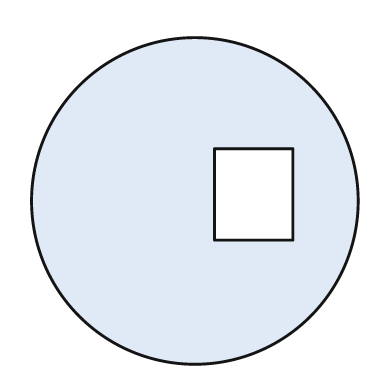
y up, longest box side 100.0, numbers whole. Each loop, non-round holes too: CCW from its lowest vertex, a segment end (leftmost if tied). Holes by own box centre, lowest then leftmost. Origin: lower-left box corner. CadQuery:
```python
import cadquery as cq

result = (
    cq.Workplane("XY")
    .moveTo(50.0, 50.0)
    .circle(50.0)
    .moveTo(56.0, 38.0)
    .lineTo(80.0, 38.0)
    .lineTo(80.0, 66.0)
    .lineTo(56.0, 66.0)
    .close()
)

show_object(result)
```